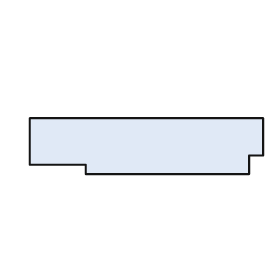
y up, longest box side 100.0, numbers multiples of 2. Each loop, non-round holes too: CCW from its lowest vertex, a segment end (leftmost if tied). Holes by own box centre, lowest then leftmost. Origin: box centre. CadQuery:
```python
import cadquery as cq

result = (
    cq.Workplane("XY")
    .moveTo(-26.0, -12.0)
    .lineTo(44.0, -12.0)
    .lineTo(44.0, -4.0)
    .lineTo(50.0, -4.0)
    .lineTo(50.0, 12.0)
    .lineTo(-50.0, 12.0)
    .lineTo(-50.0, -8.0)
    .lineTo(-26.0, -8.0)
    .close()
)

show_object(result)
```